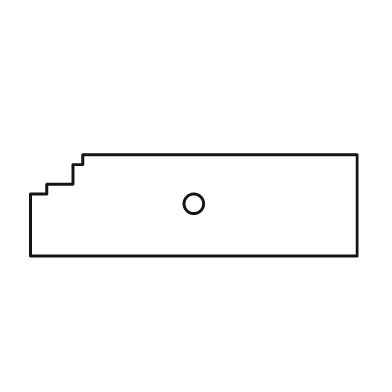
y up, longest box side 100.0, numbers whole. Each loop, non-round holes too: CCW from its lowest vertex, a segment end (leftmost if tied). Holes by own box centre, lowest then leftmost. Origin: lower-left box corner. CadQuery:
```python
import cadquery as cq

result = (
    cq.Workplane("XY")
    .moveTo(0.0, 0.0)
    .lineTo(100.0, 0.0)
    .lineTo(100.0, 31.0)
    .lineTo(16.0, 31.0)
    .lineTo(16.0, 28.0)
    .lineTo(13.0, 28.0)
    .lineTo(13.0, 22.0)
    .lineTo(5.0, 22.0)
    .lineTo(5.0, 19.0)
    .lineTo(0.0, 19.0)
    .close()
    .moveTo(50.0, 16.0)
    .circle(3.0)
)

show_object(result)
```